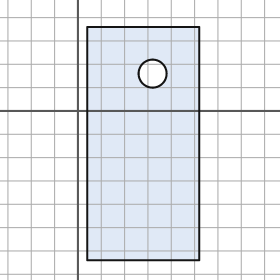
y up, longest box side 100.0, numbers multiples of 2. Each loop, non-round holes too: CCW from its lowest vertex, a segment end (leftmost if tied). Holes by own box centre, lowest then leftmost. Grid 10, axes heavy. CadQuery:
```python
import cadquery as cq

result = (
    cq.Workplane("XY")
    .moveTo(4.0, -64.0)
    .lineTo(52.0, -64.0)
    .lineTo(52.0, 36.0)
    .lineTo(4.0, 36.0)
    .close()
    .moveTo(32.0, 16.0)
    .circle(6.0)
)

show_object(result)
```